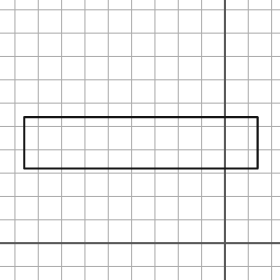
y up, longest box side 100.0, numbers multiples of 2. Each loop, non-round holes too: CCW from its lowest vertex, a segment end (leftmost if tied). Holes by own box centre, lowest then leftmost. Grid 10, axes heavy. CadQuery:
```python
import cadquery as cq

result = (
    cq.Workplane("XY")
    .moveTo(-86.0, 32.0)
    .lineTo(14.0, 32.0)
    .lineTo(14.0, 54.0)
    .lineTo(-86.0, 54.0)
    .close()
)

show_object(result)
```